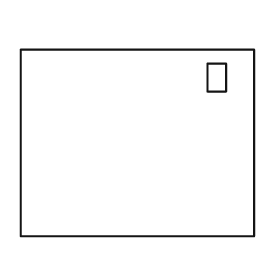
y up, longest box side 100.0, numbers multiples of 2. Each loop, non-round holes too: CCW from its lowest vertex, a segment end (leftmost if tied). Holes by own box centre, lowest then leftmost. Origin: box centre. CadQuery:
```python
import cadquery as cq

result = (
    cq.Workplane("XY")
    .moveTo(-50.0, -40.0)
    .lineTo(50.0, -40.0)
    .lineTo(50.0, 40.0)
    .lineTo(-50.0, 40.0)
    .close()
    .moveTo(30.0, 22.0)
    .lineTo(38.0, 22.0)
    .lineTo(38.0, 34.0)
    .lineTo(30.0, 34.0)
    .close()
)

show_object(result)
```